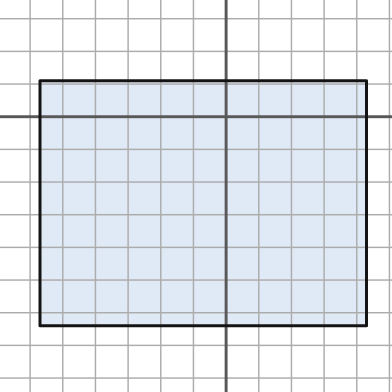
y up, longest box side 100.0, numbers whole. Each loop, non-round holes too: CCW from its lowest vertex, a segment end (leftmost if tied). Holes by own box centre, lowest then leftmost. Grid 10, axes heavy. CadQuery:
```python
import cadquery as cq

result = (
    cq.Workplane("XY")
    .moveTo(-57.0, -64.0)
    .lineTo(43.0, -64.0)
    .lineTo(43.0, 11.0)
    .lineTo(-57.0, 11.0)
    .close()
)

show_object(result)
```